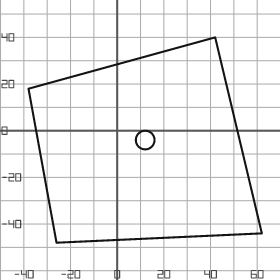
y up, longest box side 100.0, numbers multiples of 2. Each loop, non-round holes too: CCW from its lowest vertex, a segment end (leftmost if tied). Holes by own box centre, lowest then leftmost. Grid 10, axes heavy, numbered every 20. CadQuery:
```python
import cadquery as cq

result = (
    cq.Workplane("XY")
    .moveTo(-26.0, -48.0)
    .lineTo(62.0, -44.0)
    .lineTo(42.0, 40.0)
    .lineTo(-38.0, 18.0)
    .close()
    .moveTo(12.0, -4.0)
    .circle(4.0)
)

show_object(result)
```